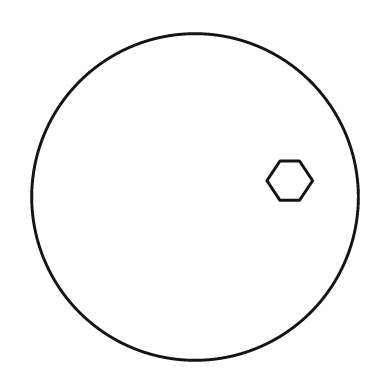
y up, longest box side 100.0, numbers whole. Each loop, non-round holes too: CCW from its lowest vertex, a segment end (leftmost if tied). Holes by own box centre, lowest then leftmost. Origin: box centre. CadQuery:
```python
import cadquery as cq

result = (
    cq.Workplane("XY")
    .moveTo(0.0, 0.0)
    .circle(50.0)
    .moveTo(26.0, -1.0)
    .lineTo(32.0, -1.0)
    .lineTo(36.0, 5.0)
    .lineTo(32.0, 11.0)
    .lineTo(26.0, 11.0)
    .lineTo(22.0, 5.0)
    .close()
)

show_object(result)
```